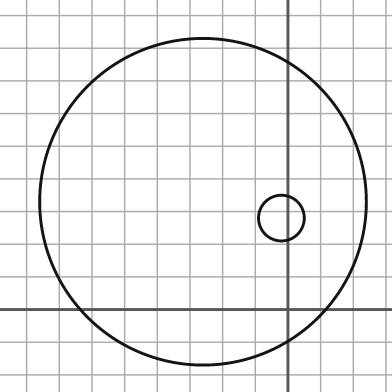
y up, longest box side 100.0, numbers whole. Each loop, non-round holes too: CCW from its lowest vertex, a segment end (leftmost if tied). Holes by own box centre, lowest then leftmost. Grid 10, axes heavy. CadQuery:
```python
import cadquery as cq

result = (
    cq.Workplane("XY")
    .moveTo(-26.0, 33.0)
    .circle(50.0)
    .moveTo(-2.0, 28.0)
    .circle(7.0)
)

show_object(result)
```